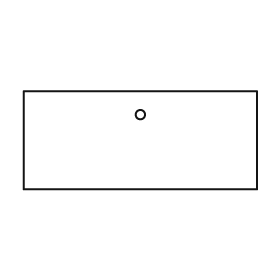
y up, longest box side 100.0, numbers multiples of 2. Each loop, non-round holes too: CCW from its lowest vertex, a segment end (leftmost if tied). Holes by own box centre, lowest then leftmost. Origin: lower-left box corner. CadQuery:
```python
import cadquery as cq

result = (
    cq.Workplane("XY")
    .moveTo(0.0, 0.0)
    .lineTo(100.0, 0.0)
    .lineTo(100.0, 42.0)
    .lineTo(0.0, 42.0)
    .close()
    .moveTo(50.0, 32.0)
    .circle(2.0)
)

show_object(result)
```